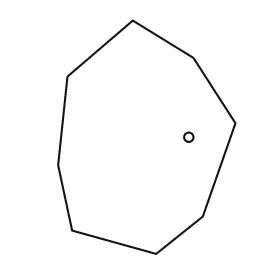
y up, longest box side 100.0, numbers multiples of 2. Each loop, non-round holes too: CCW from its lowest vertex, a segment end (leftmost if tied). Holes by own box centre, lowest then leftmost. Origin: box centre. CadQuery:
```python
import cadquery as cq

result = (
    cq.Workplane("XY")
    .moveTo(4.0, -50.0)
    .lineTo(24.0, -34.0)
    .lineTo(38.0, 6.0)
    .lineTo(20.0, 34.0)
    .lineTo(-6.0, 50.0)
    .lineTo(-34.0, 26.0)
    .lineTo(-38.0, -12.0)
    .lineTo(-32.0, -40.0)
    .close()
    .moveTo(18.0, 0.0)
    .circle(2.0)
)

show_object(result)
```